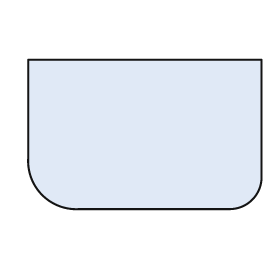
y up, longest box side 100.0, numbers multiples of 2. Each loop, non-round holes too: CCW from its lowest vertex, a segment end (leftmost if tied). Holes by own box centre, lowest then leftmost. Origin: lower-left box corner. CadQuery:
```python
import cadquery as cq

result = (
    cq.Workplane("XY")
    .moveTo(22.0, 0.0)
    .lineTo(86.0, 0.0)
    .threePointArc((96.0, 4.0), (100.0, 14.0))
    .lineTo(100.0, 64.0)
    .lineTo(0.0, 64.0)
    .lineTo(0.0, 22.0)
    .threePointArc((6.0, 6.0), (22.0, 0.0))
    .close()
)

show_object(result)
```